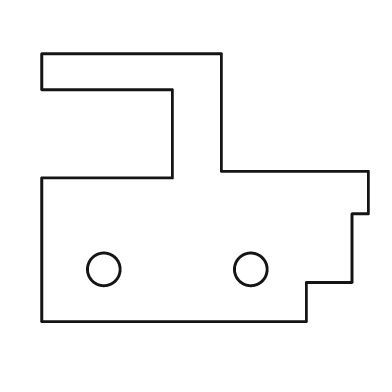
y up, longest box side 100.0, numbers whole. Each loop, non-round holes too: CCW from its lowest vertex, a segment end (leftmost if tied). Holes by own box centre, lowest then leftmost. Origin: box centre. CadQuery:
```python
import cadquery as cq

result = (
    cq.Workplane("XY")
    .moveTo(-50.0, -41.0)
    .lineTo(31.0, -41.0)
    .lineTo(31.0, -29.0)
    .lineTo(45.0, -29.0)
    .lineTo(45.0, -8.0)
    .lineTo(50.0, -8.0)
    .lineTo(50.0, 5.0)
    .lineTo(5.0, 5.0)
    .lineTo(5.0, 41.0)
    .lineTo(-50.0, 41.0)
    .lineTo(-50.0, 30.0)
    .lineTo(-10.0, 30.0)
    .lineTo(-10.0, 3.0)
    .lineTo(-50.0, 3.0)
    .close()
    .moveTo(-31.0, -25.0)
    .circle(5.0)
    .moveTo(14.0, -25.0)
    .circle(5.0)
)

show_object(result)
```